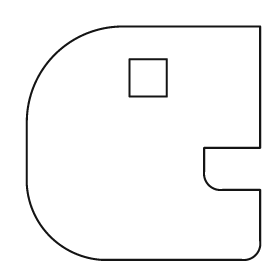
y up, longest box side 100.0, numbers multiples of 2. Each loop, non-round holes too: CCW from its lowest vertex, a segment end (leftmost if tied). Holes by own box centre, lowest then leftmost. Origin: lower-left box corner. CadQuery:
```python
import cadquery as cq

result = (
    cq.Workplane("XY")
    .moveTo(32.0, 0.0)
    .lineTo(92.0, 0.0)
    .threePointArc((98.0, 2.0), (100.0, 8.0))
    .lineTo(100.0, 30.0)
    .lineTo(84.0, 30.0)
    .threePointArc((78.0, 32.0), (76.0, 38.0))
    .lineTo(76.0, 48.0)
    .lineTo(100.0, 48.0)
    .lineTo(100.0, 100.0)
    .lineTo(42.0, 100.0)
    .threePointArc((12.0, 88.0), (0.0, 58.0))
    .lineTo(0.0, 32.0)
    .threePointArc((10.0, 10.0), (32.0, 0.0))
    .close()
    .moveTo(44.0, 70.0)
    .lineTo(60.0, 70.0)
    .lineTo(60.0, 86.0)
    .lineTo(44.0, 86.0)
    .close()
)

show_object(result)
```